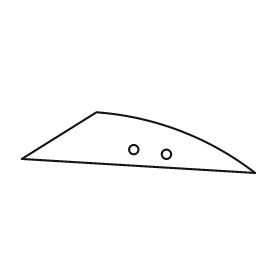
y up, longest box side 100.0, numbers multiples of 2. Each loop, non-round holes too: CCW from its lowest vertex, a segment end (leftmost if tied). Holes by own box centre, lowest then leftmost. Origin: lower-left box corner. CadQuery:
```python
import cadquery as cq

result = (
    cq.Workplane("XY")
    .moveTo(100.0, 0.0)
    .threePointArc((68.0, 18.0), (32.0, 26.0))
    .lineTo(0.0, 6.0)
    .close()
    .moveTo(62.0, 8.0)
    .circle(2.0)
    .moveTo(48.0, 10.0)
    .circle(2.0)
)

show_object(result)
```